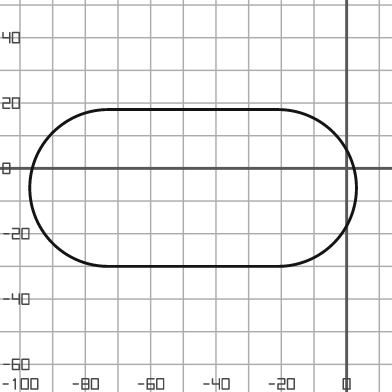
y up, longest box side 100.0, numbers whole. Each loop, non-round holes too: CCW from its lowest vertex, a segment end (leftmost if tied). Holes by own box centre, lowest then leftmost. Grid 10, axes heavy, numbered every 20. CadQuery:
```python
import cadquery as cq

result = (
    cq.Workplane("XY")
    .moveTo(-73.0, -30.0)
    .lineTo(-21.0, -30.0)
    .threePointArc((3.0, -6.0), (-21.0, 18.0))
    .lineTo(-73.0, 18.0)
    .threePointArc((-97.0, -6.0), (-73.0, -30.0))
    .close()
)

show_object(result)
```